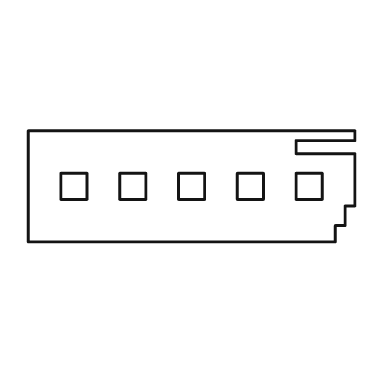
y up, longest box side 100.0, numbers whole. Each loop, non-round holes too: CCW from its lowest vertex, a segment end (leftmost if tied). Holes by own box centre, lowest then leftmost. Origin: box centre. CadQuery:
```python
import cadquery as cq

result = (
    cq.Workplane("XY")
    .moveTo(-50.0, -17.0)
    .lineTo(44.0, -17.0)
    .lineTo(44.0, -12.0)
    .lineTo(47.0, -12.0)
    .lineTo(47.0, -6.0)
    .lineTo(50.0, -6.0)
    .lineTo(50.0, 10.0)
    .lineTo(32.0, 10.0)
    .lineTo(32.0, 14.0)
    .lineTo(50.0, 14.0)
    .lineTo(50.0, 17.0)
    .lineTo(-50.0, 17.0)
    .close()
    .moveTo(-40.0, -4.0)
    .lineTo(-32.0, -4.0)
    .lineTo(-32.0, 4.0)
    .lineTo(-40.0, 4.0)
    .close()
    .moveTo(-22.0, -4.0)
    .lineTo(-14.0, -4.0)
    .lineTo(-14.0, 4.0)
    .lineTo(-22.0, 4.0)
    .close()
    .moveTo(-4.0, -4.0)
    .lineTo(4.0, -4.0)
    .lineTo(4.0, 4.0)
    .lineTo(-4.0, 4.0)
    .close()
    .moveTo(14.0, -4.0)
    .lineTo(22.0, -4.0)
    .lineTo(22.0, 4.0)
    .lineTo(14.0, 4.0)
    .close()
    .moveTo(32.0, -4.0)
    .lineTo(40.0, -4.0)
    .lineTo(40.0, 4.0)
    .lineTo(32.0, 4.0)
    .close()
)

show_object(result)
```